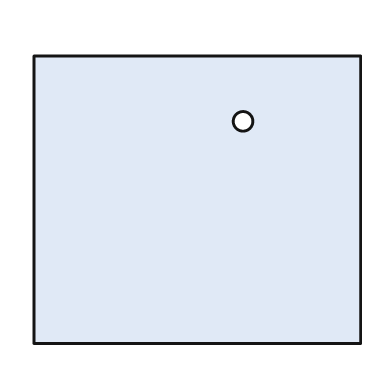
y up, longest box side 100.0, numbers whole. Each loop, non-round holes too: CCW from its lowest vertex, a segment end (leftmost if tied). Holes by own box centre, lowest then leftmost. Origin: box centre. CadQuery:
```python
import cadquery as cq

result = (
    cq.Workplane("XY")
    .moveTo(-50.0, -44.0)
    .lineTo(50.0, -44.0)
    .lineTo(50.0, 44.0)
    .lineTo(-50.0, 44.0)
    .close()
    .moveTo(14.0, 24.0)
    .circle(3.0)
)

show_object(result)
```